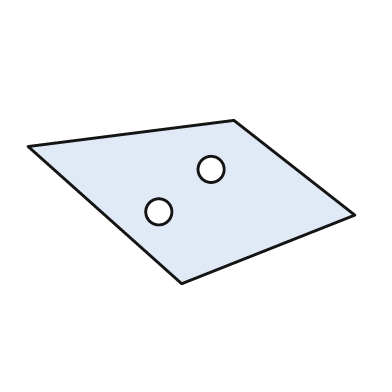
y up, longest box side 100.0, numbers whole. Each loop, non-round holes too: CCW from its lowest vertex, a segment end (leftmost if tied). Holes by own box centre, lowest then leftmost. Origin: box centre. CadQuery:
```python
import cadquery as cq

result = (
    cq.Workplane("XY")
    .moveTo(-3.0, -25.0)
    .lineTo(50.0, -4.0)
    .lineTo(13.0, 25.0)
    .lineTo(-50.0, 17.0)
    .close()
    .moveTo(-10.0, -3.0)
    .circle(4.0)
    .moveTo(6.0, 10.0)
    .circle(4.0)
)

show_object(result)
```